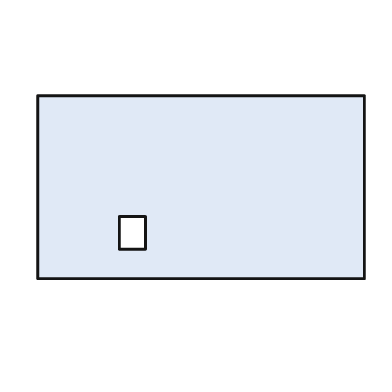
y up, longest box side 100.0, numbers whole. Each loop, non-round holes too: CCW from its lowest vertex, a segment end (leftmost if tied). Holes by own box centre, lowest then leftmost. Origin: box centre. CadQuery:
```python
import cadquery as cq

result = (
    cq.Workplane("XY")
    .moveTo(-50.0, -28.0)
    .lineTo(50.0, -28.0)
    .lineTo(50.0, 28.0)
    .lineTo(-50.0, 28.0)
    .close()
    .moveTo(-25.0, -19.0)
    .lineTo(-17.0, -19.0)
    .lineTo(-17.0, -9.0)
    .lineTo(-25.0, -9.0)
    .close()
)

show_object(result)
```